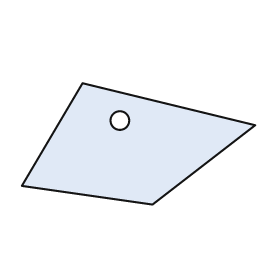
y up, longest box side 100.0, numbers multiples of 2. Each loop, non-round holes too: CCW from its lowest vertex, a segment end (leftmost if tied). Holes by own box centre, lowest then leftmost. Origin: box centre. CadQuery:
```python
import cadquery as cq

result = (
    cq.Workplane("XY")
    .moveTo(6.0, -26.0)
    .lineTo(50.0, 8.0)
    .lineTo(-24.0, 26.0)
    .lineTo(-50.0, -18.0)
    .close()
    .moveTo(-8.0, 10.0)
    .circle(4.0)
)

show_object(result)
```